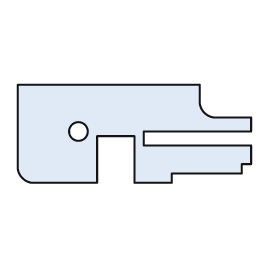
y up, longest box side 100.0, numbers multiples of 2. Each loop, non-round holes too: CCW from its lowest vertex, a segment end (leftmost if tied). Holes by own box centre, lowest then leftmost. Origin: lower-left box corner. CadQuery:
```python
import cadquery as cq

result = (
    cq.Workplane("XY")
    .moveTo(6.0, 0.0)
    .lineTo(34.0, 0.0)
    .lineTo(34.0, 20.0)
    .lineTo(50.0, 20.0)
    .lineTo(50.0, 0.0)
    .lineTo(66.0, 0.0)
    .lineTo(66.0, 4.0)
    .lineTo(96.0, 4.0)
    .lineTo(96.0, 8.0)
    .lineTo(100.0, 8.0)
    .lineTo(100.0, 16.0)
    .lineTo(54.0, 16.0)
    .lineTo(54.0, 22.0)
    .lineTo(100.0, 22.0)
    .lineTo(100.0, 28.0)
    .lineTo(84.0, 28.0)
    .threePointArc((80.0, 30.0), (78.0, 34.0))
    .lineTo(78.0, 42.0)
    .lineTo(0.0, 42.0)
    .lineTo(0.0, 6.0)
    .threePointArc((2.0, 2.0), (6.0, 0.0))
    .close()
    .moveTo(26.0, 22.0)
    .circle(4.0)
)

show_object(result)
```